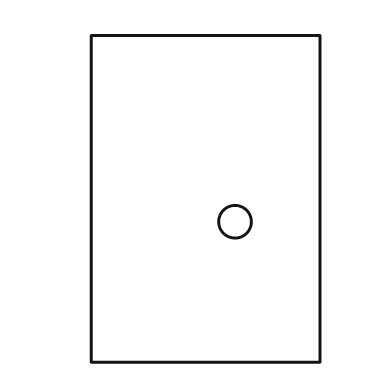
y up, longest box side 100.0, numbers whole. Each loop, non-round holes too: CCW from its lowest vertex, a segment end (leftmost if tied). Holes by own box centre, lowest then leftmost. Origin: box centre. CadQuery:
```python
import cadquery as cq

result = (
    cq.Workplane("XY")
    .moveTo(-35.0, -50.0)
    .lineTo(35.0, -50.0)
    .lineTo(35.0, 50.0)
    .lineTo(-35.0, 50.0)
    .close()
    .moveTo(9.0, -7.0)
    .circle(5.0)
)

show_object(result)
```